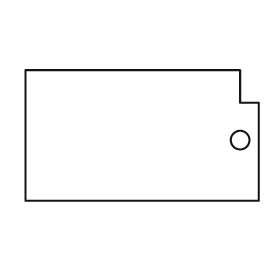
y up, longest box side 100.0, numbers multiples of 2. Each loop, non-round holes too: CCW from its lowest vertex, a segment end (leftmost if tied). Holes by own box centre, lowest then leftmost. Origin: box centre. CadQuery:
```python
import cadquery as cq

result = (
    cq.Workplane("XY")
    .moveTo(-50.0, -28.0)
    .lineTo(50.0, -28.0)
    .lineTo(50.0, 14.0)
    .lineTo(42.0, 14.0)
    .lineTo(42.0, 28.0)
    .lineTo(-50.0, 28.0)
    .close()
    .moveTo(42.0, -2.0)
    .circle(4.0)
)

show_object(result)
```